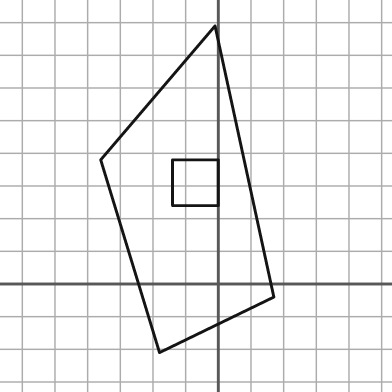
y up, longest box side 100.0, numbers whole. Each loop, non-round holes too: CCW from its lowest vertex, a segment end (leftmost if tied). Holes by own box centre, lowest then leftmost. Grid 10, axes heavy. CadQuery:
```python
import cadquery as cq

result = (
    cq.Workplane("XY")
    .moveTo(-18.0, -21.0)
    .lineTo(17.0, -4.0)
    .lineTo(-1.0, 79.0)
    .lineTo(-36.0, 38.0)
    .close()
    .moveTo(-14.0, 24.0)
    .lineTo(0.0, 24.0)
    .lineTo(0.0, 38.0)
    .lineTo(-14.0, 38.0)
    .close()
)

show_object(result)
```